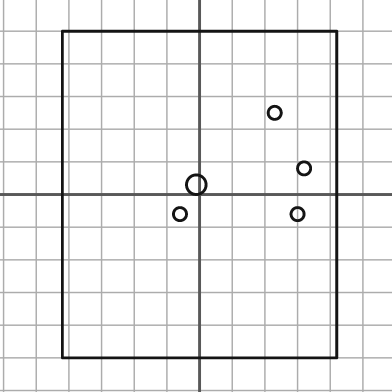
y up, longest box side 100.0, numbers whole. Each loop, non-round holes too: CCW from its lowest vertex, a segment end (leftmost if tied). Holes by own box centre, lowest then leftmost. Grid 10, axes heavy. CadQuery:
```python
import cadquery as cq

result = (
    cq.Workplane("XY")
    .moveTo(-42.0, -50.0)
    .lineTo(42.0, -50.0)
    .lineTo(42.0, 50.0)
    .lineTo(-42.0, 50.0)
    .close()
    .moveTo(-6.0, -6.0)
    .circle(2.0)
    .moveTo(30.0, -6.0)
    .circle(2.0)
    .moveTo(-1.0, 3.0)
    .circle(3.0)
    .moveTo(32.0, 8.0)
    .circle(2.0)
    .moveTo(23.0, 25.0)
    .circle(2.0)
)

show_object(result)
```